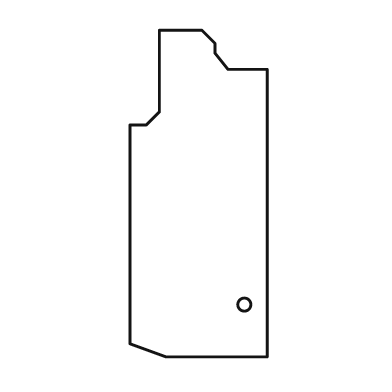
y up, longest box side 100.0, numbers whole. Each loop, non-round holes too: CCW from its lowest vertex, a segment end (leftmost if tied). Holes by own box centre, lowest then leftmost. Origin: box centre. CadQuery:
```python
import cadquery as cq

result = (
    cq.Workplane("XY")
    .moveTo(-10.0, -50.0)
    .lineTo(21.0, -50.0)
    .lineTo(21.0, 38.0)
    .lineTo(9.0, 38.0)
    .lineTo(5.0, 43.0)
    .lineTo(5.0, 46.0)
    .lineTo(1.0, 50.0)
    .lineTo(-12.0, 50.0)
    .lineTo(-12.0, 25.0)
    .lineTo(-16.0, 21.0)
    .lineTo(-21.0, 21.0)
    .lineTo(-21.0, -46.0)
    .close()
    .moveTo(14.0, -34.0)
    .circle(2.0)
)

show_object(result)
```